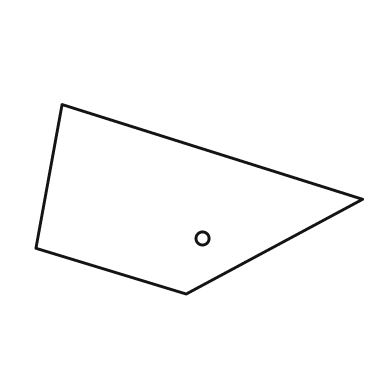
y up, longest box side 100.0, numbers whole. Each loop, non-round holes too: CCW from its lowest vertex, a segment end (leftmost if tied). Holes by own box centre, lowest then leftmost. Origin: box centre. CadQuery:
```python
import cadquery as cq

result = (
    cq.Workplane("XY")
    .moveTo(-4.0, -29.0)
    .lineTo(50.0, 0.0)
    .lineTo(-42.0, 29.0)
    .lineTo(-50.0, -15.0)
    .close()
    .moveTo(1.0, -12.0)
    .circle(2.0)
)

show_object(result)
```